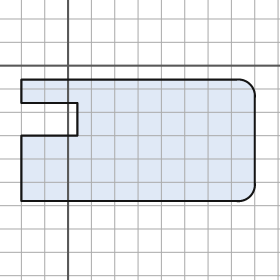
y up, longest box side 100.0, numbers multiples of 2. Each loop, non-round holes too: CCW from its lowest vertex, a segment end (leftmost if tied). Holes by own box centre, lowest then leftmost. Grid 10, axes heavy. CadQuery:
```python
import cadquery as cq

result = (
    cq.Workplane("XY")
    .moveTo(-20.0, -58.0)
    .lineTo(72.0, -58.0)
    .threePointArc((78.0, -56.0), (80.0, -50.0))
    .lineTo(80.0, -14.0)
    .threePointArc((78.0, -8.0), (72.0, -6.0))
    .lineTo(-20.0, -6.0)
    .lineTo(-20.0, -16.0)
    .lineTo(4.0, -16.0)
    .lineTo(4.0, -30.0)
    .lineTo(-20.0, -30.0)
    .close()
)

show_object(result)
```